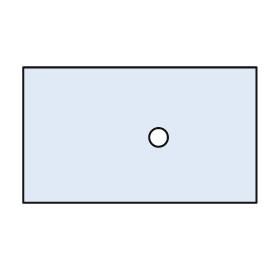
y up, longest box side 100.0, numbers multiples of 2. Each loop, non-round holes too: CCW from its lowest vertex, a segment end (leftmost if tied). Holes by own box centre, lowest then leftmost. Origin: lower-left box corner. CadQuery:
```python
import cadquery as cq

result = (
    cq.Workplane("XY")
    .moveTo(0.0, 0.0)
    .lineTo(100.0, 0.0)
    .lineTo(100.0, 58.0)
    .lineTo(0.0, 58.0)
    .close()
    .moveTo(58.0, 28.0)
    .circle(4.0)
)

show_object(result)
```